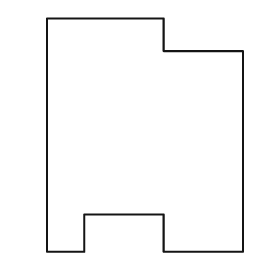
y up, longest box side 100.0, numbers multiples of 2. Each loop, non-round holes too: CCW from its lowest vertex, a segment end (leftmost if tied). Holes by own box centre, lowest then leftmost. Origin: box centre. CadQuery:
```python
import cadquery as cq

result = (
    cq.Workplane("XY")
    .moveTo(-42.0, -50.0)
    .lineTo(-26.0, -50.0)
    .lineTo(-26.0, -34.0)
    .lineTo(8.0, -34.0)
    .lineTo(8.0, -50.0)
    .lineTo(42.0, -50.0)
    .lineTo(42.0, 36.0)
    .lineTo(8.0, 36.0)
    .lineTo(8.0, 50.0)
    .lineTo(-42.0, 50.0)
    .close()
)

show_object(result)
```